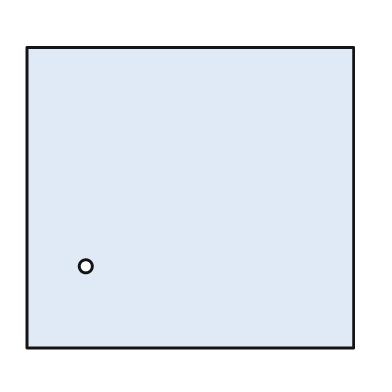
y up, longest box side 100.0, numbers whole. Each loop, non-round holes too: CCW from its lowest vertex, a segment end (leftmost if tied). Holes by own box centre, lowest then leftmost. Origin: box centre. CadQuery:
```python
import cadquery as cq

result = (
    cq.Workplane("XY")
    .moveTo(-50.0, -46.0)
    .lineTo(50.0, -46.0)
    .lineTo(50.0, 46.0)
    .lineTo(-50.0, 46.0)
    .close()
    .moveTo(-32.0, -21.0)
    .circle(2.0)
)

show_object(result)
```